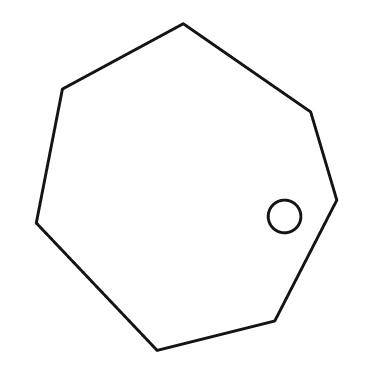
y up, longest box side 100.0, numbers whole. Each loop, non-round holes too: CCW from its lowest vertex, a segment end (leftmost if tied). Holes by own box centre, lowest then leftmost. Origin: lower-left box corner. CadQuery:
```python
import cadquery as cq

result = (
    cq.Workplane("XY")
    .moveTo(37.0, 0.0)
    .lineTo(73.0, 9.0)
    .lineTo(92.0, 46.0)
    .lineTo(84.0, 73.0)
    .lineTo(45.0, 100.0)
    .lineTo(8.0, 80.0)
    .lineTo(0.0, 39.0)
    .close()
    .moveTo(76.0, 41.0)
    .circle(5.0)
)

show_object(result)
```